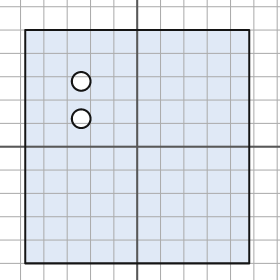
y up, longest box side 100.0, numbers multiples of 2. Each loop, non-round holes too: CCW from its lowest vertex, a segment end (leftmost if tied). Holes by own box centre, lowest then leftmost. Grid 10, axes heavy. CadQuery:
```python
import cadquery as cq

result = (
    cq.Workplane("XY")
    .moveTo(-48.0, -50.0)
    .lineTo(48.0, -50.0)
    .lineTo(48.0, 50.0)
    .lineTo(-48.0, 50.0)
    .close()
    .moveTo(-24.0, 12.0)
    .circle(4.0)
    .moveTo(-24.0, 28.0)
    .circle(4.0)
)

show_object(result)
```